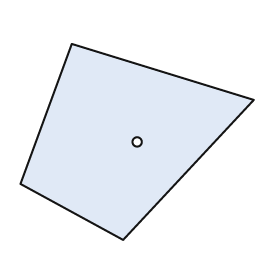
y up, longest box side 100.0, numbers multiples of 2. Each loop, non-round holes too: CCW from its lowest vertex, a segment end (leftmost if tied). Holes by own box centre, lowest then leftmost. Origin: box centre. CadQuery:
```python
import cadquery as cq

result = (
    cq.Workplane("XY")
    .moveTo(-6.0, -42.0)
    .lineTo(50.0, 18.0)
    .lineTo(-28.0, 42.0)
    .lineTo(-50.0, -18.0)
    .close()
    .moveTo(0.0, 0.0)
    .circle(2.0)
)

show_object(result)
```